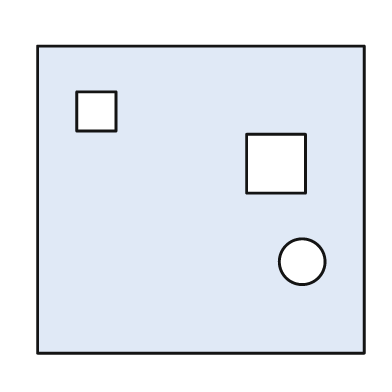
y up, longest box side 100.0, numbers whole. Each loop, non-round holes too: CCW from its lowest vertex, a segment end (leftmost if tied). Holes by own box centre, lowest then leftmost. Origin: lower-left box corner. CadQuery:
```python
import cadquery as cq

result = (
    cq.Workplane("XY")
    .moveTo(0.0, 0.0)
    .lineTo(100.0, 0.0)
    .lineTo(100.0, 94.0)
    .lineTo(0.0, 94.0)
    .close()
    .moveTo(81.0, 28.0)
    .circle(7.0)
    .moveTo(64.0, 49.0)
    .lineTo(82.0, 49.0)
    .lineTo(82.0, 67.0)
    .lineTo(64.0, 67.0)
    .close()
    .moveTo(12.0, 68.0)
    .lineTo(24.0, 68.0)
    .lineTo(24.0, 80.0)
    .lineTo(12.0, 80.0)
    .close()
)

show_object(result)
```